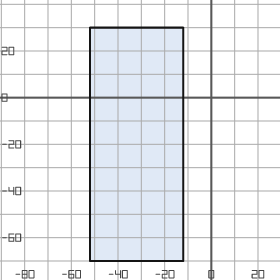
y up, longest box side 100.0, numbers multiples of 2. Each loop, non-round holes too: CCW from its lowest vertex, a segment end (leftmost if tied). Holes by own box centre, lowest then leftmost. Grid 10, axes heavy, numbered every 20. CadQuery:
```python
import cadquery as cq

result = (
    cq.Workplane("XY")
    .moveTo(-52.0, -70.0)
    .lineTo(-12.0, -70.0)
    .lineTo(-12.0, 30.0)
    .lineTo(-52.0, 30.0)
    .close()
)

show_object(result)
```